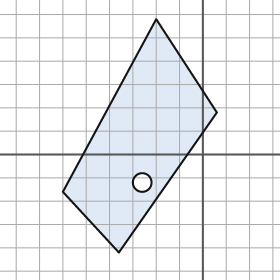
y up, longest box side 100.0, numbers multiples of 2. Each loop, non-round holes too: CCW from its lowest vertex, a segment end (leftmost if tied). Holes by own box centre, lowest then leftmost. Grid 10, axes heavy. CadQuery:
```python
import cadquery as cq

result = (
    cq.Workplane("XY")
    .moveTo(-36.0, -42.0)
    .lineTo(6.0, 18.0)
    .lineTo(-20.0, 58.0)
    .lineTo(-60.0, -16.0)
    .close()
    .moveTo(-26.0, -12.0)
    .circle(4.0)
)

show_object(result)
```